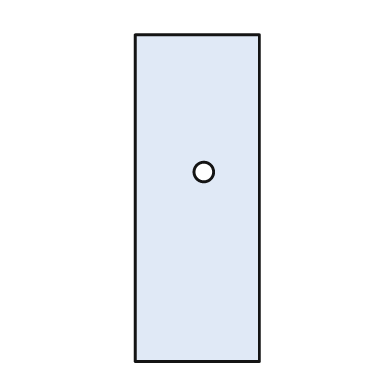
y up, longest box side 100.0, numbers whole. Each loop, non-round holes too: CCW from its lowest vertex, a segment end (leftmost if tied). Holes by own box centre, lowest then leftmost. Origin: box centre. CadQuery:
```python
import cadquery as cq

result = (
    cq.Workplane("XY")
    .moveTo(-19.0, -50.0)
    .lineTo(19.0, -50.0)
    .lineTo(19.0, 50.0)
    .lineTo(-19.0, 50.0)
    .close()
    .moveTo(2.0, 8.0)
    .circle(3.0)
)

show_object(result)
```